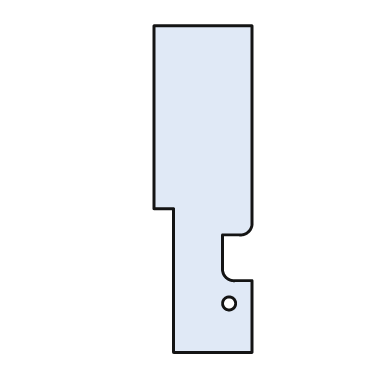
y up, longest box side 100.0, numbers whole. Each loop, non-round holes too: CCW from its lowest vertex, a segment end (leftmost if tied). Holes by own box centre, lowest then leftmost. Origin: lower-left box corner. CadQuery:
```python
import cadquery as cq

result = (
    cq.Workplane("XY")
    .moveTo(6.0, 0.0)
    .lineTo(30.0, 0.0)
    .lineTo(30.0, 22.0)
    .lineTo(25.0, 22.0)
    .threePointArc((22.0, 23.0), (21.0, 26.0))
    .lineTo(21.0, 36.0)
    .lineTo(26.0, 36.0)
    .threePointArc((29.0, 37.0), (30.0, 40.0))
    .lineTo(30.0, 100.0)
    .lineTo(0.0, 100.0)
    .lineTo(0.0, 44.0)
    .lineTo(6.0, 44.0)
    .close()
    .moveTo(23.0, 15.0)
    .circle(2.0)
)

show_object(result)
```